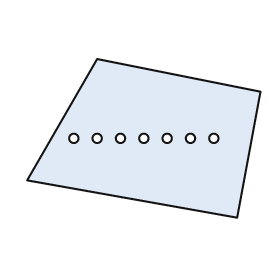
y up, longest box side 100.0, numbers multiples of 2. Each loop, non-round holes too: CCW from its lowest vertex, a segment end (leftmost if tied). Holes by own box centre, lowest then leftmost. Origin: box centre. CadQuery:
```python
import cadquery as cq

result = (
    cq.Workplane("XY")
    .moveTo(40.0, -34.0)
    .lineTo(50.0, 20.0)
    .lineTo(-20.0, 34.0)
    .lineTo(-50.0, -18.0)
    .close()
    .moveTo(-30.0, 0.0)
    .circle(2.0)
    .moveTo(-20.0, 0.0)
    .circle(2.0)
    .moveTo(-10.0, 0.0)
    .circle(2.0)
    .moveTo(0.0, 0.0)
    .circle(2.0)
    .moveTo(10.0, 0.0)
    .circle(2.0)
    .moveTo(20.0, 0.0)
    .circle(2.0)
    .moveTo(30.0, 0.0)
    .circle(2.0)
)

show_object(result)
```